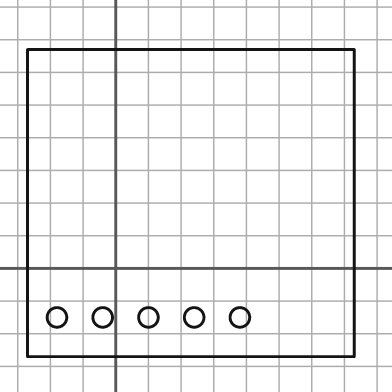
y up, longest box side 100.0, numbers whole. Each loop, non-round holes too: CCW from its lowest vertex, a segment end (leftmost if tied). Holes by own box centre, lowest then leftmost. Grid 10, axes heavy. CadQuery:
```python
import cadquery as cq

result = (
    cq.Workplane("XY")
    .moveTo(-27.0, -27.0)
    .lineTo(73.0, -27.0)
    .lineTo(73.0, 67.0)
    .lineTo(-27.0, 67.0)
    .close()
    .moveTo(-18.0, -15.0)
    .circle(3.0)
    .moveTo(-4.0, -15.0)
    .circle(3.0)
    .moveTo(10.0, -15.0)
    .circle(3.0)
    .moveTo(24.0, -15.0)
    .circle(3.0)
    .moveTo(38.0, -15.0)
    .circle(3.0)
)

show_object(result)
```